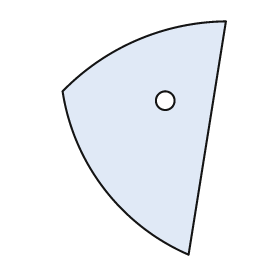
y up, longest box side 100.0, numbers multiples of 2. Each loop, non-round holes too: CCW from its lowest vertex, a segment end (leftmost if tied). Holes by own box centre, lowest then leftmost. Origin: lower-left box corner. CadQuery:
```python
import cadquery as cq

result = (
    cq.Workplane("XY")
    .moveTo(54.0, 0.0)
    .lineTo(70.0, 100.0)
    .threePointArc((32.0, 92.0), (0.0, 70.0))
    .threePointArc((18.0, 28.0), (54.0, 0.0))
    .close()
    .moveTo(44.0, 66.0)
    .circle(4.0)
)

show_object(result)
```